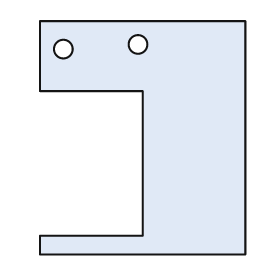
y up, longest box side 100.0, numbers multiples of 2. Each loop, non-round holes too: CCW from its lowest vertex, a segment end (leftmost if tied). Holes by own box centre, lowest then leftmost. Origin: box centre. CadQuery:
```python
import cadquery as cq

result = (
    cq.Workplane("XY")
    .moveTo(-44.0, -50.0)
    .lineTo(44.0, -50.0)
    .lineTo(44.0, 50.0)
    .lineTo(-44.0, 50.0)
    .lineTo(-44.0, 20.0)
    .lineTo(0.0, 20.0)
    .lineTo(0.0, -42.0)
    .lineTo(-44.0, -42.0)
    .close()
    .moveTo(-34.0, 38.0)
    .circle(4.0)
    .moveTo(-2.0, 40.0)
    .circle(4.0)
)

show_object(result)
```